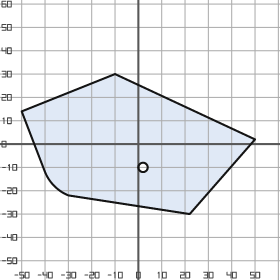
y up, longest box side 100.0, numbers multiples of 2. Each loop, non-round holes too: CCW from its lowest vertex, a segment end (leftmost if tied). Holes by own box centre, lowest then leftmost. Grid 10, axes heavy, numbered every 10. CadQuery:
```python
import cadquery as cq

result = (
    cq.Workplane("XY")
    .moveTo(22.0, -30.0)
    .lineTo(50.0, 2.0)
    .lineTo(-10.0, 30.0)
    .lineTo(-50.0, 14.0)
    .lineTo(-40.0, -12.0)
    .threePointArc((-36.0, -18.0), (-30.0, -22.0))
    .close()
    .moveTo(2.0, -10.0)
    .circle(2.0)
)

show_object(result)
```